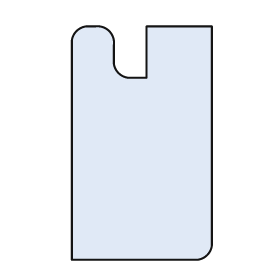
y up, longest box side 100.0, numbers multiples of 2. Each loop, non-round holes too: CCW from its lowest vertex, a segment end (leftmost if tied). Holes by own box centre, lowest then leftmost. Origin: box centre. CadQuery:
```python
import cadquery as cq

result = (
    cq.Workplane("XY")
    .moveTo(-30.0, -50.0)
    .lineTo(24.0, -50.0)
    .threePointArc((28.0, -48.0), (30.0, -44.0))
    .lineTo(30.0, 50.0)
    .lineTo(2.0, 50.0)
    .lineTo(2.0, 28.0)
    .lineTo(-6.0, 28.0)
    .threePointArc((-10.0, 30.0), (-12.0, 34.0))
    .lineTo(-12.0, 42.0)
    .threePointArc((-14.0, 48.0), (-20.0, 50.0))
    .lineTo(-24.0, 50.0)
    .threePointArc((-28.0, 48.0), (-30.0, 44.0))
    .close()
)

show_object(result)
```